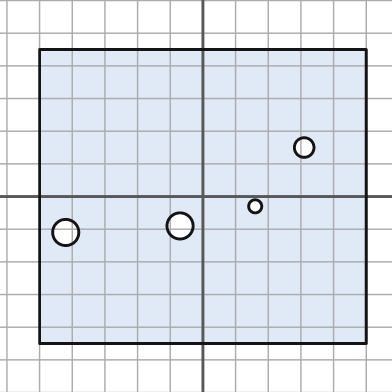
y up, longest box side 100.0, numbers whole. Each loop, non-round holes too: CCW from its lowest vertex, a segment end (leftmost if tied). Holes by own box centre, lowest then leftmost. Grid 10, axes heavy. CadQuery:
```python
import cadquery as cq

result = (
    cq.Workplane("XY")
    .moveTo(-50.0, -45.0)
    .lineTo(50.0, -45.0)
    .lineTo(50.0, 45.0)
    .lineTo(-50.0, 45.0)
    .close()
    .moveTo(-42.0, -11.0)
    .circle(4.0)
    .moveTo(-7.0, -9.0)
    .circle(4.0)
    .moveTo(16.0, -3.0)
    .circle(2.0)
    .moveTo(31.0, 15.0)
    .circle(3.0)
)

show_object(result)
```